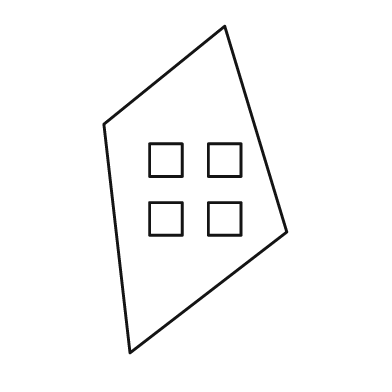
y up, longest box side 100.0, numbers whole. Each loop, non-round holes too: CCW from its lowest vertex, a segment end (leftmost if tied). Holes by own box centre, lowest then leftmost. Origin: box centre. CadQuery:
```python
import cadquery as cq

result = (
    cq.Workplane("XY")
    .moveTo(-20.0, -50.0)
    .lineTo(28.0, -13.0)
    .lineTo(9.0, 50.0)
    .lineTo(-28.0, 20.0)
    .close()
    .moveTo(-14.0, -14.0)
    .lineTo(-4.0, -14.0)
    .lineTo(-4.0, -4.0)
    .lineTo(-14.0, -4.0)
    .close()
    .moveTo(4.0, -14.0)
    .lineTo(14.0, -14.0)
    .lineTo(14.0, -4.0)
    .lineTo(4.0, -4.0)
    .close()
    .moveTo(-14.0, 4.0)
    .lineTo(-4.0, 4.0)
    .lineTo(-4.0, 14.0)
    .lineTo(-14.0, 14.0)
    .close()
    .moveTo(4.0, 4.0)
    .lineTo(14.0, 4.0)
    .lineTo(14.0, 14.0)
    .lineTo(4.0, 14.0)
    .close()
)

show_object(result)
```